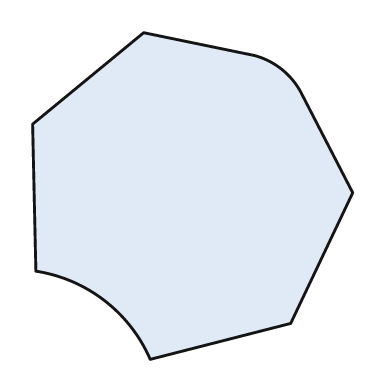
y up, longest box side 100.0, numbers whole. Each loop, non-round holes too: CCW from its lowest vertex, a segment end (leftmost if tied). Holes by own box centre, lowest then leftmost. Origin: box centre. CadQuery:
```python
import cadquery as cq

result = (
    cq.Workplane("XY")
    .moveTo(-13.0, -50.0)
    .lineTo(30.0, -39.0)
    .lineTo(49.0, 1.0)
    .lineTo(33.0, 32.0)
    .threePointArc((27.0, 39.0), (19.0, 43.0))
    .lineTo(-15.0, 50.0)
    .lineTo(-49.0, 22.0)
    .lineTo(-48.0, -23.0)
    .threePointArc((-27.0, -32.0), (-13.0, -50.0))
    .close()
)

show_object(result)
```